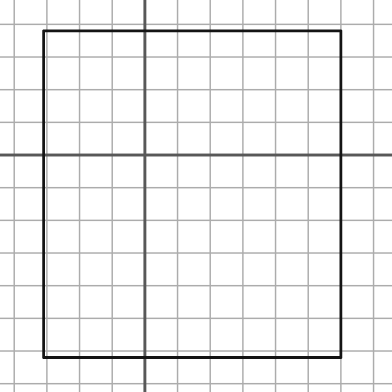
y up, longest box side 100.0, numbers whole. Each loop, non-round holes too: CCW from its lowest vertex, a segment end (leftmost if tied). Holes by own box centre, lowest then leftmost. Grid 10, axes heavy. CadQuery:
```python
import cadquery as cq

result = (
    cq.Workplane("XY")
    .moveTo(-31.0, -62.0)
    .lineTo(60.0, -62.0)
    .lineTo(60.0, 38.0)
    .lineTo(-31.0, 38.0)
    .close()
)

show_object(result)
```